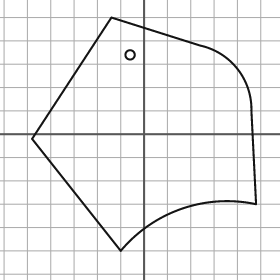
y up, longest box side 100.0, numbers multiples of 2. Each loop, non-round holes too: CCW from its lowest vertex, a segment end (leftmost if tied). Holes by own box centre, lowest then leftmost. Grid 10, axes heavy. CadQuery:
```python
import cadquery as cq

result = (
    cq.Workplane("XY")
    .moveTo(-10.0, -50.0)
    .threePointArc((16.0, -32.0), (48.0, -30.0))
    .lineTo(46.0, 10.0)
    .threePointArc((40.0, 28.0), (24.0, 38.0))
    .lineTo(-14.0, 50.0)
    .lineTo(-48.0, -2.0)
    .close()
    .moveTo(-6.0, 34.0)
    .circle(2.0)
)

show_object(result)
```